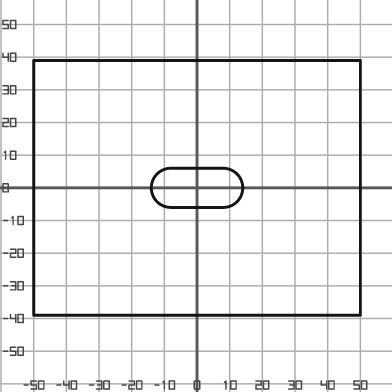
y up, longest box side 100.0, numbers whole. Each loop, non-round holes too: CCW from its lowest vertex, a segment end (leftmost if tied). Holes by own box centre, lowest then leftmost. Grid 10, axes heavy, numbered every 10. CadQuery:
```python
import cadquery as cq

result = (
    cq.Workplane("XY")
    .moveTo(-50.0, -39.0)
    .lineTo(50.0, -39.0)
    .lineTo(50.0, 39.0)
    .lineTo(-50.0, 39.0)
    .close()
    .moveTo(-8.0, -6.0)
    .lineTo(8.0, -6.0)
    .threePointArc((14.0, 0.0), (8.0, 6.0))
    .lineTo(-8.0, 6.0)
    .threePointArc((-14.0, 0.0), (-8.0, -6.0))
    .close()
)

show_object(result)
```